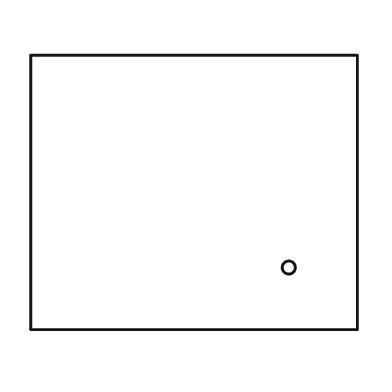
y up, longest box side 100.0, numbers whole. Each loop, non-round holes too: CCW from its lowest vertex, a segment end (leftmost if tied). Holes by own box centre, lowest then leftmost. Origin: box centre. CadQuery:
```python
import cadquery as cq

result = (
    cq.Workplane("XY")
    .moveTo(-50.0, -42.0)
    .lineTo(50.0, -42.0)
    .lineTo(50.0, 42.0)
    .lineTo(-50.0, 42.0)
    .close()
    .moveTo(29.0, -23.0)
    .circle(2.0)
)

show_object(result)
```